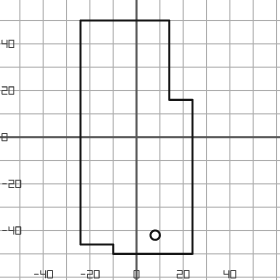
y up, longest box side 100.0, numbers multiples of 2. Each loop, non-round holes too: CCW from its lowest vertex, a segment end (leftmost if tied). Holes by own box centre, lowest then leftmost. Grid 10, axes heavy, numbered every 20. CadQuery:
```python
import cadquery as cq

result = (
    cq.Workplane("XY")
    .moveTo(-10.0, -50.0)
    .lineTo(24.0, -50.0)
    .lineTo(24.0, 16.0)
    .lineTo(14.0, 16.0)
    .lineTo(14.0, 50.0)
    .lineTo(-24.0, 50.0)
    .lineTo(-24.0, -46.0)
    .lineTo(-10.0, -46.0)
    .close()
    .moveTo(8.0, -42.0)
    .circle(2.0)
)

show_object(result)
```